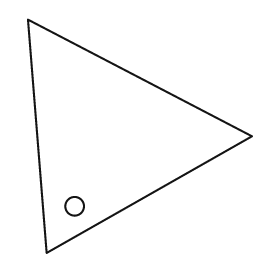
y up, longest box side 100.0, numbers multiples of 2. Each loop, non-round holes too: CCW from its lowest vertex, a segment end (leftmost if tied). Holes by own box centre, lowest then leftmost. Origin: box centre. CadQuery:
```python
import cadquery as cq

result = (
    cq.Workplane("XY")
    .moveTo(-40.0, -50.0)
    .lineTo(48.0, 0.0)
    .lineTo(-48.0, 50.0)
    .close()
    .moveTo(-28.0, -30.0)
    .circle(4.0)
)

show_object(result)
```